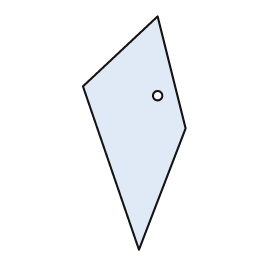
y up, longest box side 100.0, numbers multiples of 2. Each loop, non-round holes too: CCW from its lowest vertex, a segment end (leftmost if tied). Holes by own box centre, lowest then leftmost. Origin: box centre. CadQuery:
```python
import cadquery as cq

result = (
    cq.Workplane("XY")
    .moveTo(2.0, -50.0)
    .lineTo(22.0, 2.0)
    .lineTo(10.0, 50.0)
    .lineTo(-22.0, 20.0)
    .close()
    .moveTo(10.0, 16.0)
    .circle(2.0)
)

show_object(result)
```